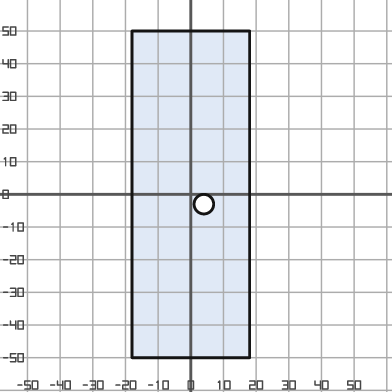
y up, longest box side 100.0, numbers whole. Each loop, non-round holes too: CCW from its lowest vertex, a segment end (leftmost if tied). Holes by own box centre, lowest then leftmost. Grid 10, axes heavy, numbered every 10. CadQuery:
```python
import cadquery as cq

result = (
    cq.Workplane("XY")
    .moveTo(-18.0, -50.0)
    .lineTo(18.0, -50.0)
    .lineTo(18.0, 50.0)
    .lineTo(-18.0, 50.0)
    .close()
    .moveTo(4.0, -3.0)
    .circle(3.0)
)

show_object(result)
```